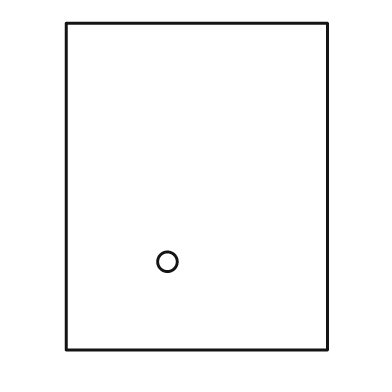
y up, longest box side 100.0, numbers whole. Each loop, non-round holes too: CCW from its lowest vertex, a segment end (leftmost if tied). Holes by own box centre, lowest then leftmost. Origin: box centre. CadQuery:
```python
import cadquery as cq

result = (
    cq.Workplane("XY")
    .moveTo(-40.0, -50.0)
    .lineTo(40.0, -50.0)
    .lineTo(40.0, 50.0)
    .lineTo(-40.0, 50.0)
    .close()
    .moveTo(-9.0, -23.0)
    .circle(3.0)
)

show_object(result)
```